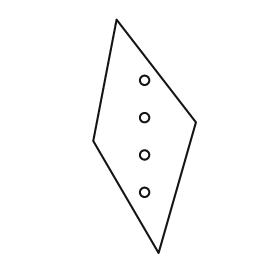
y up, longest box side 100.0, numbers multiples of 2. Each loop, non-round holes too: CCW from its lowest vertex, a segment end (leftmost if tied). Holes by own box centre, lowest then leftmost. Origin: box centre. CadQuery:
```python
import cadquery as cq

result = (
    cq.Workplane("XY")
    .moveTo(6.0, -50.0)
    .lineTo(22.0, 6.0)
    .lineTo(-12.0, 50.0)
    .lineTo(-22.0, -2.0)
    .close()
    .moveTo(0.0, -24.0)
    .circle(2.0)
    .moveTo(0.0, -8.0)
    .circle(2.0)
    .moveTo(0.0, 8.0)
    .circle(2.0)
    .moveTo(0.0, 24.0)
    .circle(2.0)
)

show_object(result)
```